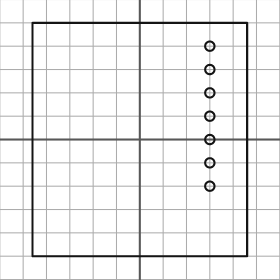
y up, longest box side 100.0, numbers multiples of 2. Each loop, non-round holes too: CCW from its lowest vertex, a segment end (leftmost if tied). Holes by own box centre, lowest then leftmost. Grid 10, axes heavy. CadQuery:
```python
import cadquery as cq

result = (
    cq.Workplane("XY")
    .moveTo(-46.0, -50.0)
    .lineTo(46.0, -50.0)
    .lineTo(46.0, 50.0)
    .lineTo(-46.0, 50.0)
    .close()
    .moveTo(30.0, -20.0)
    .circle(2.0)
    .moveTo(30.0, -10.0)
    .circle(2.0)
    .moveTo(30.0, 0.0)
    .circle(2.0)
    .moveTo(30.0, 10.0)
    .circle(2.0)
    .moveTo(30.0, 20.0)
    .circle(2.0)
    .moveTo(30.0, 30.0)
    .circle(2.0)
    .moveTo(30.0, 40.0)
    .circle(2.0)
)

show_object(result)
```